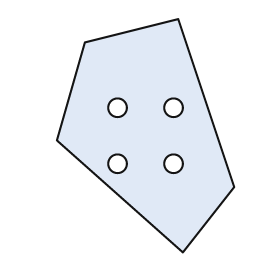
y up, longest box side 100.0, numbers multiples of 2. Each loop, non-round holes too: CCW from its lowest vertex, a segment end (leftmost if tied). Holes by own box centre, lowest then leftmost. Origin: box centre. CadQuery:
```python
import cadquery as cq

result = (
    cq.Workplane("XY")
    .moveTo(16.0, -50.0)
    .lineTo(38.0, -22.0)
    .lineTo(14.0, 50.0)
    .lineTo(-26.0, 40.0)
    .lineTo(-38.0, -2.0)
    .close()
    .moveTo(-12.0, -12.0)
    .circle(4.0)
    .moveTo(12.0, -12.0)
    .circle(4.0)
    .moveTo(-12.0, 12.0)
    .circle(4.0)
    .moveTo(12.0, 12.0)
    .circle(4.0)
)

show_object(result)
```